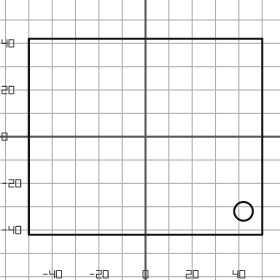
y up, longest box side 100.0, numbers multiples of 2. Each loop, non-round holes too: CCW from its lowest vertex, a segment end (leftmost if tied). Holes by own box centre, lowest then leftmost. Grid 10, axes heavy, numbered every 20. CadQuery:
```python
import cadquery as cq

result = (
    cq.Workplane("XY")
    .moveTo(-50.0, -42.0)
    .lineTo(50.0, -42.0)
    .lineTo(50.0, 42.0)
    .lineTo(-50.0, 42.0)
    .close()
    .moveTo(42.0, -32.0)
    .circle(4.0)
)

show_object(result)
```